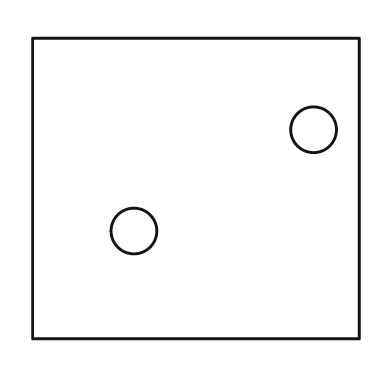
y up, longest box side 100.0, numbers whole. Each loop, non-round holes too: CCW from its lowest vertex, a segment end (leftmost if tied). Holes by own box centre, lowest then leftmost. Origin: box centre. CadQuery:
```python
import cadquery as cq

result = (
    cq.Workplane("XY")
    .moveTo(-50.0, -46.0)
    .lineTo(50.0, -46.0)
    .lineTo(50.0, 46.0)
    .lineTo(-50.0, 46.0)
    .close()
    .moveTo(-19.0, -13.0)
    .circle(7.0)
    .moveTo(36.0, 18.0)
    .circle(7.0)
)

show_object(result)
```